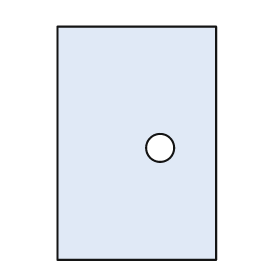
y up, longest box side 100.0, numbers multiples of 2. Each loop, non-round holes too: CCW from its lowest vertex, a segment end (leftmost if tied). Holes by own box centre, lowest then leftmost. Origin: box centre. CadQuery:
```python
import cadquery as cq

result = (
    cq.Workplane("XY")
    .moveTo(-34.0, -50.0)
    .lineTo(34.0, -50.0)
    .lineTo(34.0, 50.0)
    .lineTo(-34.0, 50.0)
    .close()
    .moveTo(10.0, -2.0)
    .circle(6.0)
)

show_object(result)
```